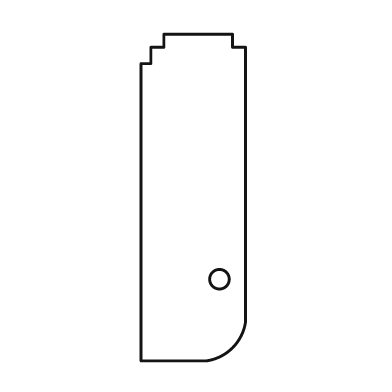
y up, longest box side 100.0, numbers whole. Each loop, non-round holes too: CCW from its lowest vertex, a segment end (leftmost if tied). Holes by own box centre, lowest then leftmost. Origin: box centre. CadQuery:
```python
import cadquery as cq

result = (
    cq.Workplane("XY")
    .moveTo(-16.0, -50.0)
    .lineTo(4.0, -50.0)
    .threePointArc((12.0, -46.0), (16.0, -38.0))
    .lineTo(16.0, 46.0)
    .lineTo(12.0, 46.0)
    .lineTo(12.0, 50.0)
    .lineTo(-9.0, 50.0)
    .lineTo(-9.0, 46.0)
    .lineTo(-13.0, 46.0)
    .lineTo(-13.0, 41.0)
    .lineTo(-16.0, 41.0)
    .close()
    .moveTo(8.0, -25.0)
    .circle(3.0)
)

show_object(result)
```